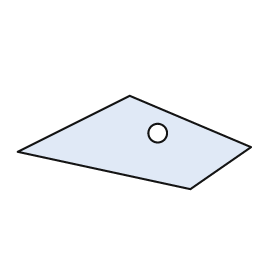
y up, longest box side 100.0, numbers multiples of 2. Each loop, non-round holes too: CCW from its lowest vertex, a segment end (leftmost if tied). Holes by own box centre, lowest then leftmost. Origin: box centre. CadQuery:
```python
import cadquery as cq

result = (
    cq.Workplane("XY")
    .moveTo(24.0, -20.0)
    .lineTo(50.0, -2.0)
    .lineTo(-2.0, 20.0)
    .lineTo(-50.0, -4.0)
    .close()
    .moveTo(10.0, 4.0)
    .circle(4.0)
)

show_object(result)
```